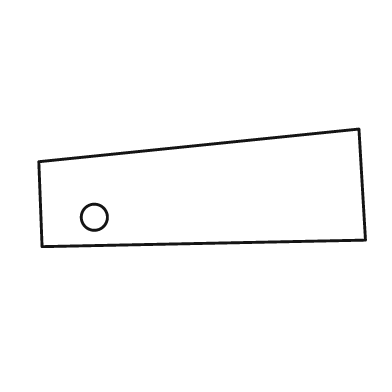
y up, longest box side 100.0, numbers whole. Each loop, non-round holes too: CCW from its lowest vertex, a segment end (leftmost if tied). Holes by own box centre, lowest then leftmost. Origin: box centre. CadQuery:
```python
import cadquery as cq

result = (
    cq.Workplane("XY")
    .moveTo(-49.0, -18.0)
    .lineTo(50.0, -16.0)
    .lineTo(48.0, 18.0)
    .lineTo(-50.0, 8.0)
    .close()
    .moveTo(-33.0, -9.0)
    .circle(4.0)
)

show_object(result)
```